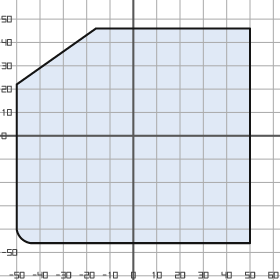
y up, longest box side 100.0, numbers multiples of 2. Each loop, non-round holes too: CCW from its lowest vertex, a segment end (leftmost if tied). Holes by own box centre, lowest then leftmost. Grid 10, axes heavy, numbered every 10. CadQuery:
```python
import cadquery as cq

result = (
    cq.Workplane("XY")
    .moveTo(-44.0, -46.0)
    .lineTo(50.0, -46.0)
    .lineTo(50.0, 46.0)
    .lineTo(-16.0, 46.0)
    .lineTo(-50.0, 22.0)
    .lineTo(-50.0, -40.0)
    .threePointArc((-48.0, -44.0), (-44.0, -46.0))
    .close()
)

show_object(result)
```